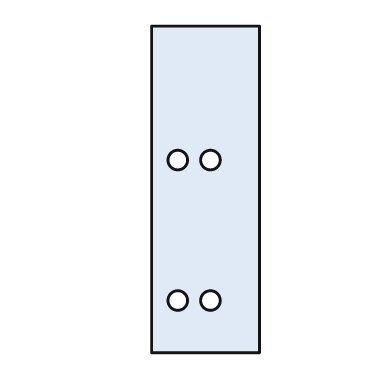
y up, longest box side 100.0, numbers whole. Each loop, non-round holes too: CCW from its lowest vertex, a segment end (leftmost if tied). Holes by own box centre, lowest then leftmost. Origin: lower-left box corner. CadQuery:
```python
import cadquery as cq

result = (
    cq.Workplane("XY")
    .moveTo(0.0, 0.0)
    .lineTo(33.0, 0.0)
    .lineTo(33.0, 100.0)
    .lineTo(0.0, 100.0)
    .close()
    .moveTo(8.0, 16.0)
    .circle(3.0)
    .moveTo(18.0, 16.0)
    .circle(3.0)
    .moveTo(8.0, 59.0)
    .circle(3.0)
    .moveTo(18.0, 59.0)
    .circle(3.0)
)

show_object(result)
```